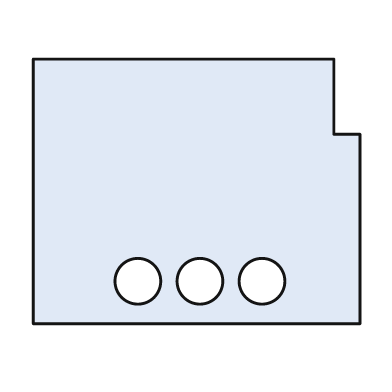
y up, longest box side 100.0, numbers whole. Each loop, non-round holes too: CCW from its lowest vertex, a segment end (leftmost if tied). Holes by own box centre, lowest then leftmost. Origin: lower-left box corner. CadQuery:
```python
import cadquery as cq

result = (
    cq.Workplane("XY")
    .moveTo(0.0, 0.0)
    .lineTo(100.0, 0.0)
    .lineTo(100.0, 58.0)
    .lineTo(92.0, 58.0)
    .lineTo(92.0, 81.0)
    .lineTo(0.0, 81.0)
    .close()
    .moveTo(32.0, 13.0)
    .circle(7.0)
    .moveTo(51.0, 13.0)
    .circle(7.0)
    .moveTo(70.0, 13.0)
    .circle(7.0)
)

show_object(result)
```